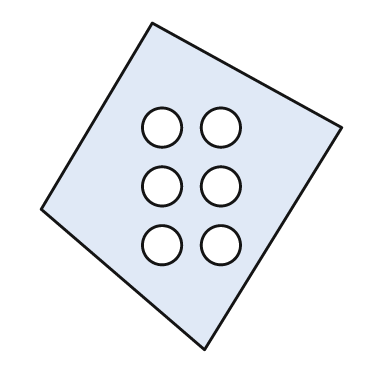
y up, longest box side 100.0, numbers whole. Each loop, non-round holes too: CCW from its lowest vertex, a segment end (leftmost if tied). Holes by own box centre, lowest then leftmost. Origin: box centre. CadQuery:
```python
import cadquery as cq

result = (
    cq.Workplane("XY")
    .moveTo(4.0, -50.0)
    .lineTo(46.0, 18.0)
    .lineTo(-12.0, 50.0)
    .lineTo(-46.0, -7.0)
    .close()
    .moveTo(-9.0, -18.0)
    .circle(6.0)
    .moveTo(9.0, -18.0)
    .circle(6.0)
    .moveTo(-9.0, 0.0)
    .circle(6.0)
    .moveTo(9.0, 0.0)
    .circle(6.0)
    .moveTo(-9.0, 18.0)
    .circle(6.0)
    .moveTo(9.0, 18.0)
    .circle(6.0)
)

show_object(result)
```